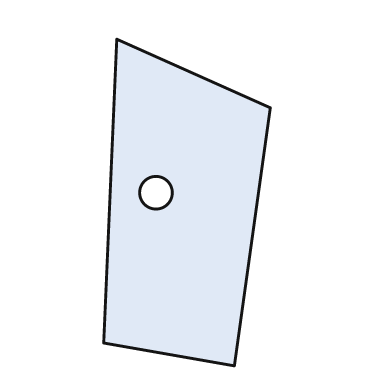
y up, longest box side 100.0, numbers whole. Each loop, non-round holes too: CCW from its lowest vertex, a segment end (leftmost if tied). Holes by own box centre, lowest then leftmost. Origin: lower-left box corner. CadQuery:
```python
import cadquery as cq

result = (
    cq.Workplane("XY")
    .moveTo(40.0, 0.0)
    .lineTo(51.0, 79.0)
    .lineTo(4.0, 100.0)
    .lineTo(0.0, 7.0)
    .close()
    .moveTo(16.0, 53.0)
    .circle(5.0)
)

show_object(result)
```